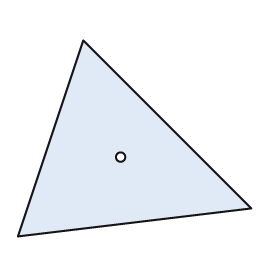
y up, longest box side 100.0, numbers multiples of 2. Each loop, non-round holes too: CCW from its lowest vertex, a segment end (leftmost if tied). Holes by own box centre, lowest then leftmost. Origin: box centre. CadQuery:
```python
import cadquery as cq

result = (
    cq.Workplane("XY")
    .moveTo(-50.0, -42.0)
    .lineTo(50.0, -30.0)
    .lineTo(-22.0, 42.0)
    .close()
    .moveTo(-6.0, -8.0)
    .circle(2.0)
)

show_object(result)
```